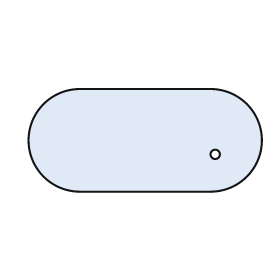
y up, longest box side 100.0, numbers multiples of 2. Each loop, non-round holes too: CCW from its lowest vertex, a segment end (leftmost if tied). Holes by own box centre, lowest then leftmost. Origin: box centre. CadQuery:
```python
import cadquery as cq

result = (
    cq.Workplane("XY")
    .moveTo(-28.0, -22.0)
    .lineTo(28.0, -22.0)
    .threePointArc((50.0, 0.0), (28.0, 22.0))
    .lineTo(-28.0, 22.0)
    .threePointArc((-50.0, 0.0), (-28.0, -22.0))
    .close()
    .moveTo(30.0, -6.0)
    .circle(2.0)
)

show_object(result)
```